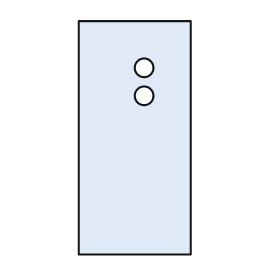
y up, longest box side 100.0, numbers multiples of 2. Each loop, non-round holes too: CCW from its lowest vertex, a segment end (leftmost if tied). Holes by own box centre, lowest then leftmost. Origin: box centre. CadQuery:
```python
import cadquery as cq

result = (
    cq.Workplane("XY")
    .moveTo(-24.0, -50.0)
    .lineTo(24.0, -50.0)
    .lineTo(24.0, 50.0)
    .lineTo(-24.0, 50.0)
    .close()
    .moveTo(4.0, 18.0)
    .circle(4.0)
    .moveTo(4.0, 30.0)
    .circle(4.0)
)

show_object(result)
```